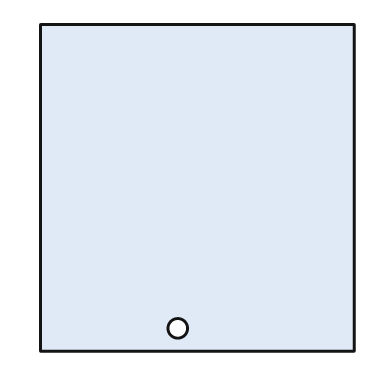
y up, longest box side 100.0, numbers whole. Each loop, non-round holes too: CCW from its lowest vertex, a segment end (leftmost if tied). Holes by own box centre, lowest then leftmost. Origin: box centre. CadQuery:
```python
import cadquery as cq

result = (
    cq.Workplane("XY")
    .moveTo(-48.0, -50.0)
    .lineTo(48.0, -50.0)
    .lineTo(48.0, 50.0)
    .lineTo(-48.0, 50.0)
    .close()
    .moveTo(-6.0, -43.0)
    .circle(3.0)
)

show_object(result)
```